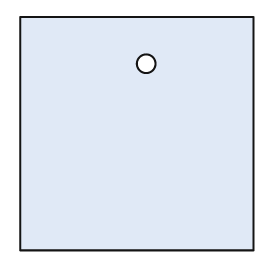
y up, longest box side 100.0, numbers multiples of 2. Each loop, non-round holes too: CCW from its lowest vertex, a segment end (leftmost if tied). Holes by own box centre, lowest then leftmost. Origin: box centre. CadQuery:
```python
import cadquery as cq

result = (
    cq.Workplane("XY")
    .moveTo(-50.0, -50.0)
    .lineTo(50.0, -50.0)
    .lineTo(50.0, 50.0)
    .lineTo(-50.0, 50.0)
    .close()
    .moveTo(4.0, 30.0)
    .circle(4.0)
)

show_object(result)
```